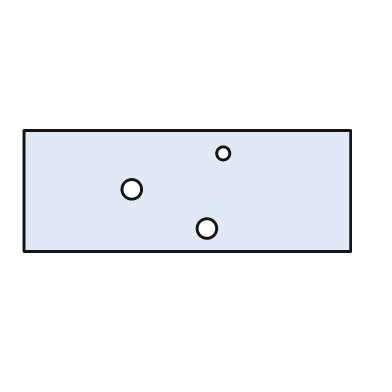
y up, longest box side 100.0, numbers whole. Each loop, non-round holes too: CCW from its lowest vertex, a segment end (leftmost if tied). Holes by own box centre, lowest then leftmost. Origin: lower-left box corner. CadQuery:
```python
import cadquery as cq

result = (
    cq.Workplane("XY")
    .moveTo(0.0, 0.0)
    .lineTo(100.0, 0.0)
    .lineTo(100.0, 37.0)
    .lineTo(0.0, 37.0)
    .close()
    .moveTo(56.0, 7.0)
    .circle(3.0)
    .moveTo(33.0, 19.0)
    .circle(3.0)
    .moveTo(61.0, 30.0)
    .circle(2.0)
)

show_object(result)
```